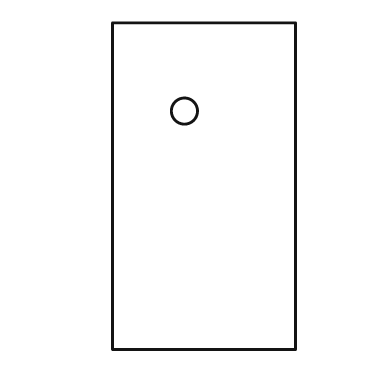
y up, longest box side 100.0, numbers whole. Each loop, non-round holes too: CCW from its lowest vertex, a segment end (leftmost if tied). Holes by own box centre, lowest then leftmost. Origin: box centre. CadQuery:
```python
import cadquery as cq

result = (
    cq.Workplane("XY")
    .moveTo(-28.0, -50.0)
    .lineTo(28.0, -50.0)
    .lineTo(28.0, 50.0)
    .lineTo(-28.0, 50.0)
    .close()
    .moveTo(-6.0, 23.0)
    .circle(4.0)
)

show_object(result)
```